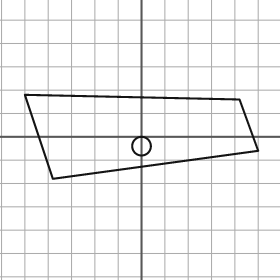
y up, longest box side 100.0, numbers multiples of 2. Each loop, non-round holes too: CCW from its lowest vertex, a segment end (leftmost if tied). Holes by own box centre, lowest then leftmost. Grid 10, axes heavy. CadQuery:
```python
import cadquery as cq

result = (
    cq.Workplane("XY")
    .moveTo(-38.0, -18.0)
    .lineTo(50.0, -6.0)
    .lineTo(42.0, 16.0)
    .lineTo(-50.0, 18.0)
    .close()
    .moveTo(0.0, -4.0)
    .circle(4.0)
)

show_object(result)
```